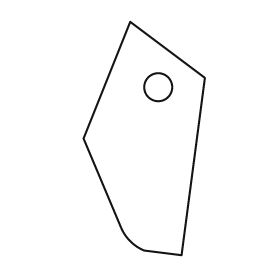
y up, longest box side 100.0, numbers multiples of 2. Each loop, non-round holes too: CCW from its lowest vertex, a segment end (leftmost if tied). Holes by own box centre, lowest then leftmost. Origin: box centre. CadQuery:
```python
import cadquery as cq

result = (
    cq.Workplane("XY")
    .moveTo(16.0, -50.0)
    .lineTo(26.0, 26.0)
    .lineTo(-6.0, 50.0)
    .lineTo(-26.0, 0.0)
    .lineTo(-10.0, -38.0)
    .threePointArc((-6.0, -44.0), (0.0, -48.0))
    .close()
    .moveTo(6.0, 22.0)
    .circle(6.0)
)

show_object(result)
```